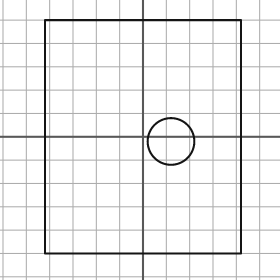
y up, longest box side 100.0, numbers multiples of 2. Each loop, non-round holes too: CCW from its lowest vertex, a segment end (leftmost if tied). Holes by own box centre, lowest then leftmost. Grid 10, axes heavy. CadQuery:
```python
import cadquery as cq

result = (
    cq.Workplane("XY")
    .moveTo(-42.0, -50.0)
    .lineTo(42.0, -50.0)
    .lineTo(42.0, 50.0)
    .lineTo(-42.0, 50.0)
    .close()
    .moveTo(12.0, -2.0)
    .circle(10.0)
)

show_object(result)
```